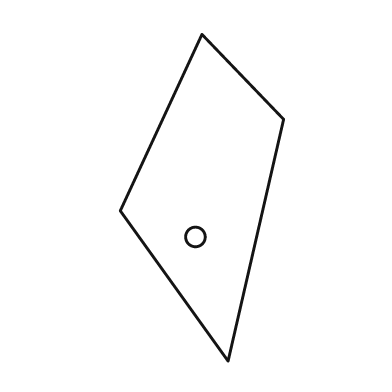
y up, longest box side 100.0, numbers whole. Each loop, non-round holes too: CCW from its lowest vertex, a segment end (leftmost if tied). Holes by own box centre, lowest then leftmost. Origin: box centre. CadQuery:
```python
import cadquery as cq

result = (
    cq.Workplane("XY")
    .moveTo(8.0, -50.0)
    .lineTo(25.0, 24.0)
    .lineTo(0.0, 50.0)
    .lineTo(-25.0, -4.0)
    .close()
    .moveTo(-2.0, -12.0)
    .circle(3.0)
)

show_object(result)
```